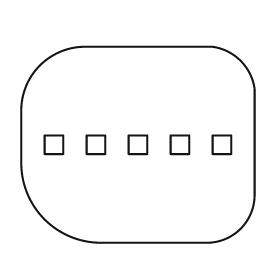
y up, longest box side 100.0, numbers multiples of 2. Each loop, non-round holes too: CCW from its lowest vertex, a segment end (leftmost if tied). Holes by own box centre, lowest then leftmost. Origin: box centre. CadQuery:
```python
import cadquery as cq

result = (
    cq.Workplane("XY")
    .moveTo(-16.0, -42.0)
    .lineTo(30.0, -42.0)
    .threePointArc((44.0, -36.0), (50.0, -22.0))
    .lineTo(50.0, 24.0)
    .threePointArc((44.0, 36.0), (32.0, 42.0))
    .lineTo(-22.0, 42.0)
    .threePointArc((-42.0, 34.0), (-50.0, 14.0))
    .lineTo(-50.0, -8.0)
    .threePointArc((-40.0, -32.0), (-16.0, -42.0))
    .close()
    .moveTo(-40.0, -4.0)
    .lineTo(-32.0, -4.0)
    .lineTo(-32.0, 4.0)
    .lineTo(-40.0, 4.0)
    .close()
    .moveTo(-22.0, -4.0)
    .lineTo(-14.0, -4.0)
    .lineTo(-14.0, 4.0)
    .lineTo(-22.0, 4.0)
    .close()
    .moveTo(-4.0, -4.0)
    .lineTo(4.0, -4.0)
    .lineTo(4.0, 4.0)
    .lineTo(-4.0, 4.0)
    .close()
    .moveTo(14.0, -4.0)
    .lineTo(22.0, -4.0)
    .lineTo(22.0, 4.0)
    .lineTo(14.0, 4.0)
    .close()
    .moveTo(32.0, -4.0)
    .lineTo(40.0, -4.0)
    .lineTo(40.0, 4.0)
    .lineTo(32.0, 4.0)
    .close()
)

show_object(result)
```